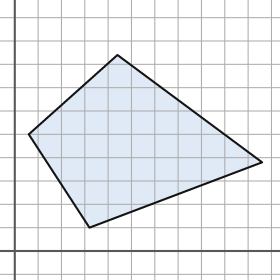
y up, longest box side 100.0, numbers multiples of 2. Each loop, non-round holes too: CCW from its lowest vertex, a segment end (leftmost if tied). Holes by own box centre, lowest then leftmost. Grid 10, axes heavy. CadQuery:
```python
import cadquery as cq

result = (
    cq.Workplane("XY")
    .moveTo(32.0, 10.0)
    .lineTo(106.0, 38.0)
    .lineTo(44.0, 84.0)
    .lineTo(6.0, 50.0)
    .close()
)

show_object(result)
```